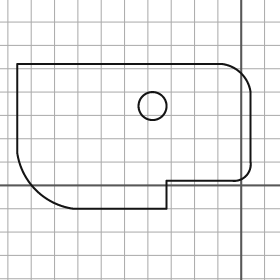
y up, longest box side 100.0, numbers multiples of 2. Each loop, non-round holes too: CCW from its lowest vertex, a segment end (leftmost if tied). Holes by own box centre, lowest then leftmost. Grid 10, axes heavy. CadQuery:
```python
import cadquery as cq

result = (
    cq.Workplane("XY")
    .moveTo(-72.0, -10.0)
    .lineTo(-32.0, -10.0)
    .lineTo(-32.0, 2.0)
    .lineTo(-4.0, 2.0)
    .threePointArc((2.0, 4.0), (4.0, 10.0))
    .lineTo(4.0, 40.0)
    .threePointArc((0.0, 48.0), (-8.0, 52.0))
    .lineTo(-96.0, 52.0)
    .lineTo(-96.0, 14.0)
    .threePointArc((-88.0, -2.0), (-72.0, -10.0))
    .close()
    .moveTo(-38.0, 34.0)
    .circle(6.0)
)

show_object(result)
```